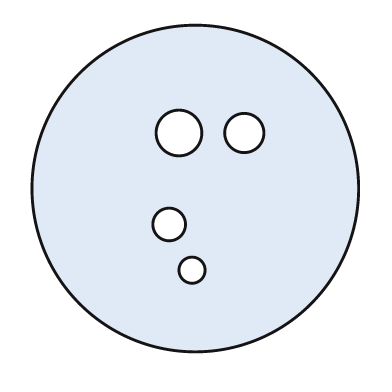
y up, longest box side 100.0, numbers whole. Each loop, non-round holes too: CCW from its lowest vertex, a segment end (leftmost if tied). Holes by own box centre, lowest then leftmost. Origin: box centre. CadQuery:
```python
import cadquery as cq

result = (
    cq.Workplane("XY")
    .moveTo(0.0, 0.0)
    .circle(50.0)
    .moveTo(-1.0, -25.0)
    .circle(4.0)
    .moveTo(-8.0, -11.0)
    .circle(5.0)
    .moveTo(-5.0, 17.0)
    .circle(7.0)
    .moveTo(15.0, 17.0)
    .circle(6.0)
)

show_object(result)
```